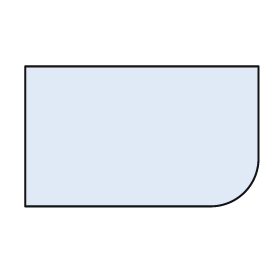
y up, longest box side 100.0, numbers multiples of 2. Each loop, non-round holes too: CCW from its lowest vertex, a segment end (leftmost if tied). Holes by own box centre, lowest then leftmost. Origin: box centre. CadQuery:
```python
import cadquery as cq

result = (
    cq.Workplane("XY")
    .moveTo(-50.0, -30.0)
    .lineTo(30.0, -30.0)
    .threePointArc((44.0, -24.0), (50.0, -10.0))
    .lineTo(50.0, 30.0)
    .lineTo(-50.0, 30.0)
    .close()
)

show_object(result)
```